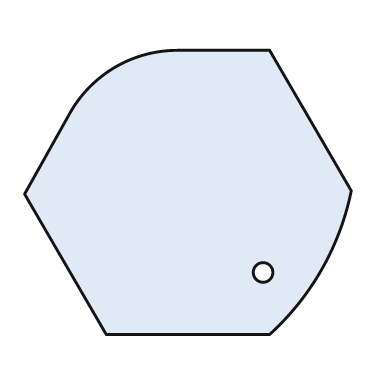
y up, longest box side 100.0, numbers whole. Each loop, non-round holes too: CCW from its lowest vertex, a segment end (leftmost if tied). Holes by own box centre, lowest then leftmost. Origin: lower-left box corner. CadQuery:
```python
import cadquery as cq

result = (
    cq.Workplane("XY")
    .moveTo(25.0, 0.0)
    .lineTo(75.0, 0.0)
    .threePointArc((91.0, 20.0), (100.0, 44.0))
    .lineTo(75.0, 87.0)
    .lineTo(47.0, 87.0)
    .threePointArc((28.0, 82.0), (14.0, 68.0))
    .lineTo(0.0, 43.0)
    .close()
    .moveTo(73.0, 19.0)
    .circle(3.0)
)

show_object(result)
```